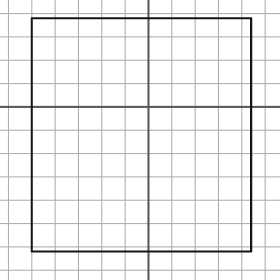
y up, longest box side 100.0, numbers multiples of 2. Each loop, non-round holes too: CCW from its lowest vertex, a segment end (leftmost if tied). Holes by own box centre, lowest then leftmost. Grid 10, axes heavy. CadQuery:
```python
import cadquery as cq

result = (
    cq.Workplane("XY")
    .moveTo(-50.0, -62.0)
    .lineTo(44.0, -62.0)
    .lineTo(44.0, 38.0)
    .lineTo(-50.0, 38.0)
    .close()
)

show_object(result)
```